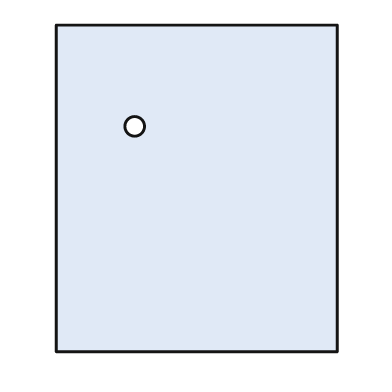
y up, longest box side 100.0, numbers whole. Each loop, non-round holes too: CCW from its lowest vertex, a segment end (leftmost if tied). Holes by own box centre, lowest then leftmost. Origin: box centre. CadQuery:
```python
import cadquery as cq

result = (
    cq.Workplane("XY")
    .moveTo(-43.0, -50.0)
    .lineTo(43.0, -50.0)
    .lineTo(43.0, 50.0)
    .lineTo(-43.0, 50.0)
    .close()
    .moveTo(-19.0, 19.0)
    .circle(3.0)
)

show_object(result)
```